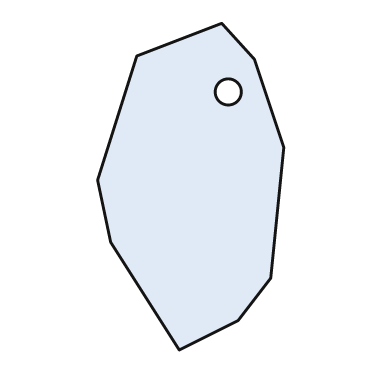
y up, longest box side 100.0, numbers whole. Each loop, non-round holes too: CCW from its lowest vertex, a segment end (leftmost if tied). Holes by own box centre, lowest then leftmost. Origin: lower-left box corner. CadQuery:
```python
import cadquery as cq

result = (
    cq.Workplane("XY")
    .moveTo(25.0, 0.0)
    .lineTo(43.0, 9.0)
    .lineTo(53.0, 22.0)
    .lineTo(57.0, 62.0)
    .lineTo(48.0, 89.0)
    .lineTo(38.0, 100.0)
    .lineTo(12.0, 90.0)
    .lineTo(0.0, 52.0)
    .lineTo(4.0, 33.0)
    .close()
    .moveTo(40.0, 79.0)
    .circle(4.0)
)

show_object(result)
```